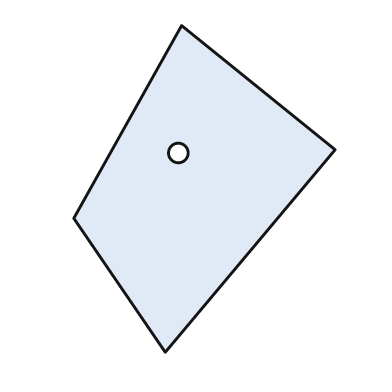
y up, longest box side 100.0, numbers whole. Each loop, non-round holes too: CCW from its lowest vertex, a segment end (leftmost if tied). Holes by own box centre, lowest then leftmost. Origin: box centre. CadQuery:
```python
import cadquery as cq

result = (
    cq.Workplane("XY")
    .moveTo(-12.0, -50.0)
    .lineTo(40.0, 12.0)
    .lineTo(-7.0, 50.0)
    .lineTo(-40.0, -9.0)
    .close()
    .moveTo(-8.0, 11.0)
    .circle(3.0)
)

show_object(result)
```